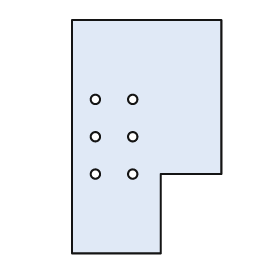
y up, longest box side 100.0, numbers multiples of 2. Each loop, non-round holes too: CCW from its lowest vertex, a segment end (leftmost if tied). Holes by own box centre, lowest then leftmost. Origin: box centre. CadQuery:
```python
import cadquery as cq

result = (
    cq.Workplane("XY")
    .moveTo(-32.0, -50.0)
    .lineTo(6.0, -50.0)
    .lineTo(6.0, -16.0)
    .lineTo(32.0, -16.0)
    .lineTo(32.0, 50.0)
    .lineTo(-32.0, 50.0)
    .close()
    .moveTo(-22.0, -16.0)
    .circle(2.0)
    .moveTo(-6.0, -16.0)
    .circle(2.0)
    .moveTo(-22.0, 0.0)
    .circle(2.0)
    .moveTo(-6.0, 0.0)
    .circle(2.0)
    .moveTo(-22.0, 16.0)
    .circle(2.0)
    .moveTo(-6.0, 16.0)
    .circle(2.0)
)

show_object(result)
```